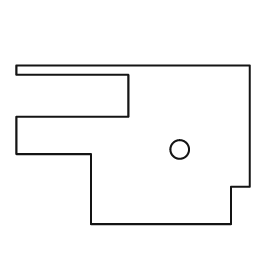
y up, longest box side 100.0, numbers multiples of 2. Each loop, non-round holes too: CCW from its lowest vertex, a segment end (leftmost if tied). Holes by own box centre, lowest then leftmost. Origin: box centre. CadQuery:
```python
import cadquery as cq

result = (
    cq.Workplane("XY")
    .moveTo(-18.0, -34.0)
    .lineTo(42.0, -34.0)
    .lineTo(42.0, -18.0)
    .lineTo(50.0, -18.0)
    .lineTo(50.0, 34.0)
    .lineTo(-50.0, 34.0)
    .lineTo(-50.0, 30.0)
    .lineTo(-2.0, 30.0)
    .lineTo(-2.0, 12.0)
    .lineTo(-50.0, 12.0)
    .lineTo(-50.0, -4.0)
    .lineTo(-18.0, -4.0)
    .close()
    .moveTo(20.0, -2.0)
    .circle(4.0)
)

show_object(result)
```